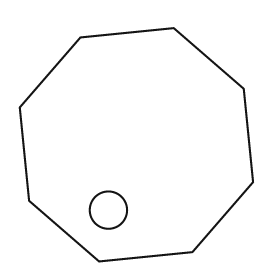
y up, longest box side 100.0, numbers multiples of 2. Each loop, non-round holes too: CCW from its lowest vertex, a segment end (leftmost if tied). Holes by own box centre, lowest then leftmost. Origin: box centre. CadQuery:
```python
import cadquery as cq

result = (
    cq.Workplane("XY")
    .moveTo(-16.0, -50.0)
    .lineTo(24.0, -46.0)
    .lineTo(50.0, -16.0)
    .lineTo(46.0, 24.0)
    .lineTo(16.0, 50.0)
    .lineTo(-24.0, 46.0)
    .lineTo(-50.0, 16.0)
    .lineTo(-46.0, -24.0)
    .close()
    .moveTo(-12.0, -28.0)
    .circle(8.0)
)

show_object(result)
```